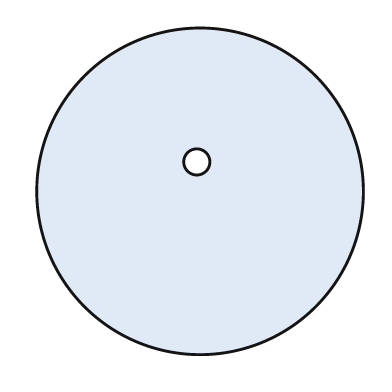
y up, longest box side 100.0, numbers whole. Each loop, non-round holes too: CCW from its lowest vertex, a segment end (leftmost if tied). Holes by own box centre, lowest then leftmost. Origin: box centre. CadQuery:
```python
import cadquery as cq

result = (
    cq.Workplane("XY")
    .moveTo(0.0, 0.0)
    .circle(50.0)
    .moveTo(-1.0, 9.0)
    .circle(4.0)
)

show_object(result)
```